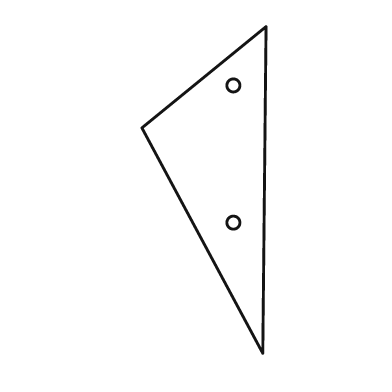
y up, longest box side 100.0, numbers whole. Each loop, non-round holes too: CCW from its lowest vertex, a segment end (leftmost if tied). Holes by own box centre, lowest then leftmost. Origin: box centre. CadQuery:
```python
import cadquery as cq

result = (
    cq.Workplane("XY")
    .moveTo(18.0, -50.0)
    .lineTo(19.0, 50.0)
    .lineTo(-19.0, 19.0)
    .close()
    .moveTo(9.0, -10.0)
    .circle(2.0)
    .moveTo(9.0, 32.0)
    .circle(2.0)
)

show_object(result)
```